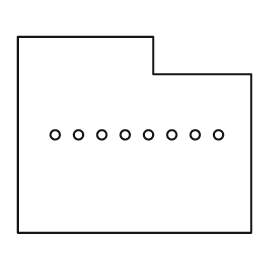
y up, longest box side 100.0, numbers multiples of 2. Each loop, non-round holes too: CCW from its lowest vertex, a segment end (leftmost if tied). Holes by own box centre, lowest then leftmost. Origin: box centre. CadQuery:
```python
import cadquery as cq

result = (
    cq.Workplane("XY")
    .moveTo(-50.0, -42.0)
    .lineTo(50.0, -42.0)
    .lineTo(50.0, 26.0)
    .lineTo(8.0, 26.0)
    .lineTo(8.0, 42.0)
    .lineTo(-50.0, 42.0)
    .close()
    .moveTo(-34.0, 0.0)
    .circle(2.0)
    .moveTo(-24.0, 0.0)
    .circle(2.0)
    .moveTo(-14.0, 0.0)
    .circle(2.0)
    .moveTo(-4.0, 0.0)
    .circle(2.0)
    .moveTo(6.0, 0.0)
    .circle(2.0)
    .moveTo(16.0, 0.0)
    .circle(2.0)
    .moveTo(26.0, 0.0)
    .circle(2.0)
    .moveTo(36.0, 0.0)
    .circle(2.0)
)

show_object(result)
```